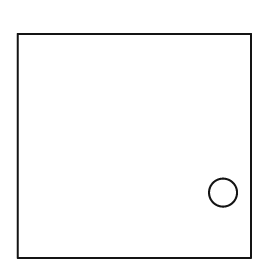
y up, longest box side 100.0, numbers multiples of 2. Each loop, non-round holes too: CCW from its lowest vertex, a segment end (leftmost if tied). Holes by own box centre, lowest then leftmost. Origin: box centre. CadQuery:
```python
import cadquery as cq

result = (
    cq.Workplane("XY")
    .moveTo(-50.0, -48.0)
    .lineTo(50.0, -48.0)
    .lineTo(50.0, 48.0)
    .lineTo(-50.0, 48.0)
    .close()
    .moveTo(38.0, -20.0)
    .circle(6.0)
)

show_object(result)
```